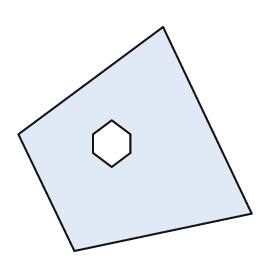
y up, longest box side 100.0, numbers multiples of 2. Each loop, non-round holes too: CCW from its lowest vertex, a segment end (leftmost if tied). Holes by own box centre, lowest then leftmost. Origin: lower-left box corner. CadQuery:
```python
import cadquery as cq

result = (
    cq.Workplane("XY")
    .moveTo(24.0, 0.0)
    .lineTo(100.0, 16.0)
    .lineTo(62.0, 96.0)
    .lineTo(0.0, 50.0)
    .close()
    .moveTo(40.0, 36.0)
    .lineTo(48.0, 42.0)
    .lineTo(48.0, 50.0)
    .lineTo(40.0, 56.0)
    .lineTo(32.0, 50.0)
    .lineTo(32.0, 42.0)
    .close()
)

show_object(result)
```